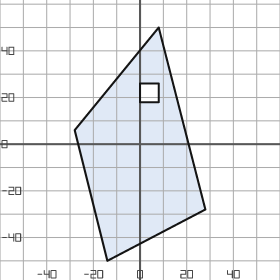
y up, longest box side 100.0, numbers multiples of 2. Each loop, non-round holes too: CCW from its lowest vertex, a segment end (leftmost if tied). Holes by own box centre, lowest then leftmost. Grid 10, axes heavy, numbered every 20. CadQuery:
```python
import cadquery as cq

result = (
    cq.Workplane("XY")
    .moveTo(-14.0, -50.0)
    .lineTo(28.0, -28.0)
    .lineTo(8.0, 50.0)
    .lineTo(-28.0, 6.0)
    .close()
    .moveTo(0.0, 18.0)
    .lineTo(8.0, 18.0)
    .lineTo(8.0, 26.0)
    .lineTo(0.0, 26.0)
    .close()
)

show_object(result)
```